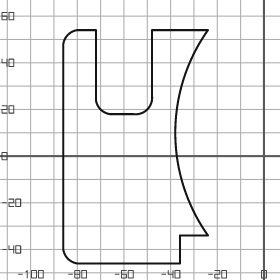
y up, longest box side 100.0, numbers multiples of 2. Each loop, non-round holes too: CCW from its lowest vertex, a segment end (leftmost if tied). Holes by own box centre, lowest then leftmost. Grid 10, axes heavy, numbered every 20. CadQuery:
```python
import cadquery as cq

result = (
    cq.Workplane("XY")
    .moveTo(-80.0, -46.0)
    .lineTo(-36.0, -46.0)
    .lineTo(-36.0, -34.0)
    .lineTo(-24.0, -34.0)
    .threePointArc((-38.0, 10.0), (-24.0, 54.0))
    .lineTo(-48.0, 54.0)
    .lineTo(-48.0, 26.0)
    .threePointArc((-50.0, 20.0), (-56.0, 18.0))
    .lineTo(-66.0, 18.0)
    .threePointArc((-70.0, 20.0), (-72.0, 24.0))
    .lineTo(-72.0, 54.0)
    .lineTo(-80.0, 54.0)
    .threePointArc((-84.0, 52.0), (-86.0, 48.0))
    .lineTo(-86.0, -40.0)
    .threePointArc((-84.0, -44.0), (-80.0, -46.0))
    .close()
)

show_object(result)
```